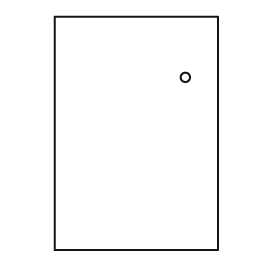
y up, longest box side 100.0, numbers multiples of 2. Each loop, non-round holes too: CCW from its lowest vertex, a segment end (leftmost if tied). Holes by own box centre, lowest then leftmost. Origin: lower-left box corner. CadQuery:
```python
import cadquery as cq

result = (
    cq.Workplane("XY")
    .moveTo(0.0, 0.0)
    .lineTo(70.0, 0.0)
    .lineTo(70.0, 100.0)
    .lineTo(0.0, 100.0)
    .close()
    .moveTo(56.0, 74.0)
    .circle(2.0)
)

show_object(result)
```